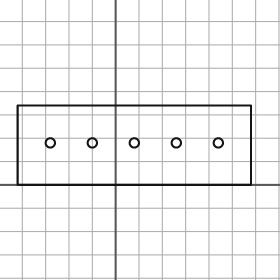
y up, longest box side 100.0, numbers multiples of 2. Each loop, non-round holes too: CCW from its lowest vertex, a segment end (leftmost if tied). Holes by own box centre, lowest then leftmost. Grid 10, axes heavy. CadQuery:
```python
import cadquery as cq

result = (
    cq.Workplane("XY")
    .moveTo(-42.0, 0.0)
    .lineTo(58.0, 0.0)
    .lineTo(58.0, 34.0)
    .lineTo(-42.0, 34.0)
    .close()
    .moveTo(-28.0, 18.0)
    .circle(2.0)
    .moveTo(-10.0, 18.0)
    .circle(2.0)
    .moveTo(8.0, 18.0)
    .circle(2.0)
    .moveTo(26.0, 18.0)
    .circle(2.0)
    .moveTo(44.0, 18.0)
    .circle(2.0)
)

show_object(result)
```